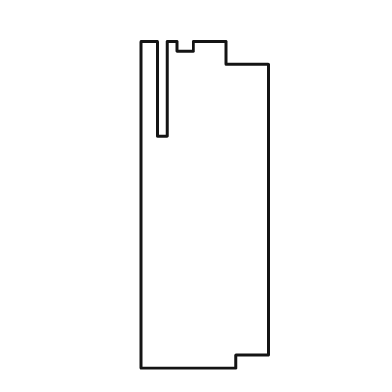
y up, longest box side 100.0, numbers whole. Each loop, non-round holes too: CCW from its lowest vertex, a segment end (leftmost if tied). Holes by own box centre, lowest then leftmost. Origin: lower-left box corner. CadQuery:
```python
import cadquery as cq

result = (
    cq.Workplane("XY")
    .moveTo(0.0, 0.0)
    .lineTo(29.0, 0.0)
    .lineTo(29.0, 4.0)
    .lineTo(39.0, 4.0)
    .lineTo(39.0, 93.0)
    .lineTo(26.0, 93.0)
    .lineTo(26.0, 100.0)
    .lineTo(16.0, 100.0)
    .lineTo(16.0, 97.0)
    .lineTo(11.0, 97.0)
    .lineTo(11.0, 100.0)
    .lineTo(8.0, 100.0)
    .lineTo(8.0, 71.0)
    .lineTo(5.0, 71.0)
    .lineTo(5.0, 100.0)
    .lineTo(0.0, 100.0)
    .close()
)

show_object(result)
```